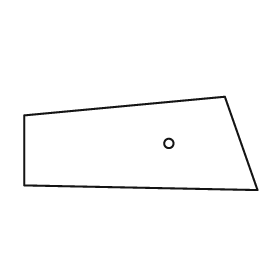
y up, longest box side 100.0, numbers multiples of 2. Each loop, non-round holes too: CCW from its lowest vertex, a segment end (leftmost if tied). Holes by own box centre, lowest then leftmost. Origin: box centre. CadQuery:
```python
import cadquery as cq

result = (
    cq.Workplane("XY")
    .moveTo(50.0, -20.0)
    .lineTo(36.0, 20.0)
    .lineTo(-50.0, 12.0)
    .lineTo(-50.0, -18.0)
    .close()
    .moveTo(12.0, 0.0)
    .circle(2.0)
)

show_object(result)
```